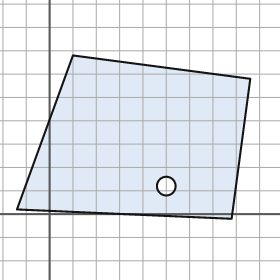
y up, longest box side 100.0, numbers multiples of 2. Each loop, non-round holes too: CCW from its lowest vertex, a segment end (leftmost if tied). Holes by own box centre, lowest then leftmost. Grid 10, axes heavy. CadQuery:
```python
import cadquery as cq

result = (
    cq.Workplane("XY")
    .moveTo(78.0, -2.0)
    .lineTo(86.0, 58.0)
    .lineTo(10.0, 68.0)
    .lineTo(-14.0, 2.0)
    .close()
    .moveTo(50.0, 12.0)
    .circle(4.0)
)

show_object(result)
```